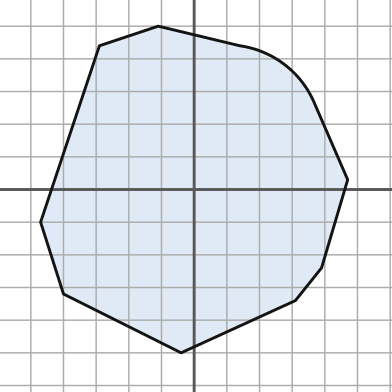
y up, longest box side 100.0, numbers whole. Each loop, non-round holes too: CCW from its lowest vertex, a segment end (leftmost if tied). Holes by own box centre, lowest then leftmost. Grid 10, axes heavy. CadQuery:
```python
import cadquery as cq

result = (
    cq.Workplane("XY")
    .moveTo(-4.0, -50.0)
    .lineTo(31.0, -34.0)
    .lineTo(39.0, -24.0)
    .lineTo(47.0, 3.0)
    .lineTo(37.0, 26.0)
    .threePointArc((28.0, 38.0), (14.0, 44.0))
    .lineTo(-11.0, 50.0)
    .lineTo(-29.0, 44.0)
    .lineTo(-47.0, -10.0)
    .lineTo(-40.0, -32.0)
    .close()
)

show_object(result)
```